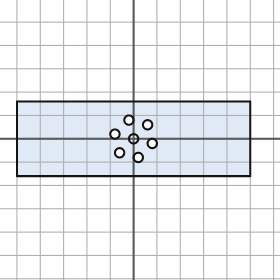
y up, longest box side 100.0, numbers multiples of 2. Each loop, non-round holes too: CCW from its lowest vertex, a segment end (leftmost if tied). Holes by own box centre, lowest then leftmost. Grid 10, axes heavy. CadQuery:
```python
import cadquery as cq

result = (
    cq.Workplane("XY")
    .moveTo(-50.0, -16.0)
    .lineTo(50.0, -16.0)
    .lineTo(50.0, 16.0)
    .lineTo(-50.0, 16.0)
    .close()
    .moveTo(2.0, -8.0)
    .circle(2.0)
    .moveTo(-6.0, -6.0)
    .circle(2.0)
    .moveTo(8.0, -2.0)
    .circle(2.0)
    .moveTo(0.0, 0.0)
    .circle(2.0)
    .moveTo(-8.0, 2.0)
    .circle(2.0)
    .moveTo(6.0, 6.0)
    .circle(2.0)
    .moveTo(-2.0, 8.0)
    .circle(2.0)
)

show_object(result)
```